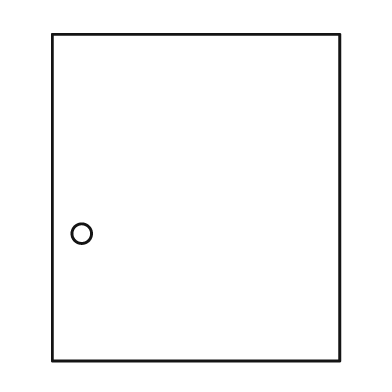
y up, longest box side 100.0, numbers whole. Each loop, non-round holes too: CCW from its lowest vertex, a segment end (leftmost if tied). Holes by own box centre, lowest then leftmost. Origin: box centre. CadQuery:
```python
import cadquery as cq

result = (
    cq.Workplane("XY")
    .moveTo(-44.0, -50.0)
    .lineTo(44.0, -50.0)
    .lineTo(44.0, 50.0)
    .lineTo(-44.0, 50.0)
    .close()
    .moveTo(-35.0, -11.0)
    .circle(3.0)
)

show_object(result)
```